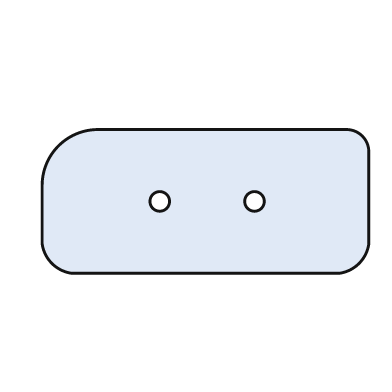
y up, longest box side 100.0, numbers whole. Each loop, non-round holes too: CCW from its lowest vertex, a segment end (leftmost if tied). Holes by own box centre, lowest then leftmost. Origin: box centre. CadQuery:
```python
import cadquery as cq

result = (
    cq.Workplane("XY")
    .moveTo(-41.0, -22.0)
    .lineTo(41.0, -22.0)
    .threePointArc((47.0, -19.0), (50.0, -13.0))
    .lineTo(50.0, 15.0)
    .threePointArc((48.0, 20.0), (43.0, 22.0))
    .lineTo(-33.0, 22.0)
    .threePointArc((-45.0, 17.0), (-50.0, 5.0))
    .lineTo(-50.0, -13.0)
    .threePointArc((-47.0, -19.0), (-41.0, -22.0))
    .close()
    .moveTo(-14.0, 0.0)
    .circle(3.0)
    .moveTo(15.0, 0.0)
    .circle(3.0)
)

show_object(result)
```